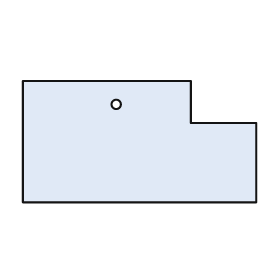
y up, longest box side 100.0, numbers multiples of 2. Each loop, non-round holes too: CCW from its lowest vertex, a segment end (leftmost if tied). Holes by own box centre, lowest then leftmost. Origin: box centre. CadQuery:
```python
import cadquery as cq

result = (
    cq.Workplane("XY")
    .moveTo(-50.0, -26.0)
    .lineTo(50.0, -26.0)
    .lineTo(50.0, 8.0)
    .lineTo(22.0, 8.0)
    .lineTo(22.0, 26.0)
    .lineTo(-50.0, 26.0)
    .close()
    .moveTo(-10.0, 16.0)
    .circle(2.0)
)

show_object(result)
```